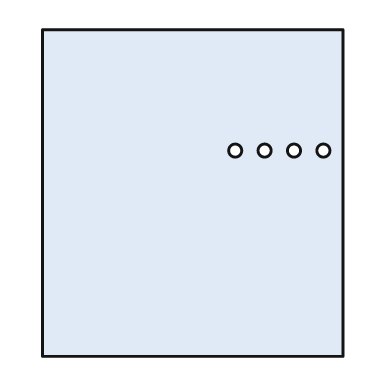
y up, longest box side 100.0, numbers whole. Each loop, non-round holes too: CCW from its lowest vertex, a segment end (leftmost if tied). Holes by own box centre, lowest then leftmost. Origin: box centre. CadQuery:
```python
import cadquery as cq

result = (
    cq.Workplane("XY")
    .moveTo(-46.0, -50.0)
    .lineTo(46.0, -50.0)
    .lineTo(46.0, 50.0)
    .lineTo(-46.0, 50.0)
    .close()
    .moveTo(13.0, 13.0)
    .circle(2.0)
    .moveTo(22.0, 13.0)
    .circle(2.0)
    .moveTo(31.0, 13.0)
    .circle(2.0)
    .moveTo(40.0, 13.0)
    .circle(2.0)
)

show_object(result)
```